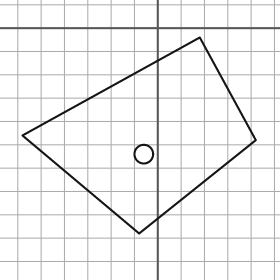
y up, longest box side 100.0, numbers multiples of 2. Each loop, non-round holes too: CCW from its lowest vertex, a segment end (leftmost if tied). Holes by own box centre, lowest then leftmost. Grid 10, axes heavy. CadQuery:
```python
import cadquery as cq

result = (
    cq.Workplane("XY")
    .moveTo(-8.0, -88.0)
    .lineTo(42.0, -48.0)
    .lineTo(18.0, -4.0)
    .lineTo(-58.0, -46.0)
    .close()
    .moveTo(-6.0, -54.0)
    .circle(4.0)
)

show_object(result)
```